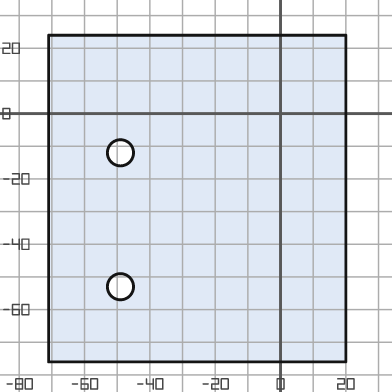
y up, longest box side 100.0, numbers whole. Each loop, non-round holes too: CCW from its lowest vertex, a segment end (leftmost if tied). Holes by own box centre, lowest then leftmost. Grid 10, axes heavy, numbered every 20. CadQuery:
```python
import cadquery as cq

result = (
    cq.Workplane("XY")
    .moveTo(-71.0, -76.0)
    .lineTo(20.0, -76.0)
    .lineTo(20.0, 24.0)
    .lineTo(-71.0, 24.0)
    .close()
    .moveTo(-49.0, -53.0)
    .circle(4.0)
    .moveTo(-49.0, -12.0)
    .circle(4.0)
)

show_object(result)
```